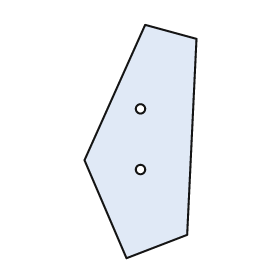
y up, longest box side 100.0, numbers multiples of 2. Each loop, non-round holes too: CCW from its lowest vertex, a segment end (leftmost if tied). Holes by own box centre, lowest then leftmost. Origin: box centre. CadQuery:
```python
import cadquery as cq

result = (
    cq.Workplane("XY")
    .moveTo(-6.0, -50.0)
    .lineTo(20.0, -40.0)
    .lineTo(24.0, 44.0)
    .lineTo(2.0, 50.0)
    .lineTo(-24.0, -8.0)
    .close()
    .moveTo(0.0, -12.0)
    .circle(2.0)
    .moveTo(0.0, 14.0)
    .circle(2.0)
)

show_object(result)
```